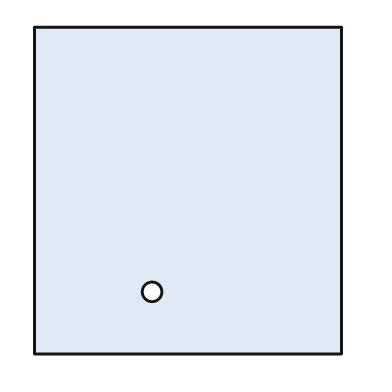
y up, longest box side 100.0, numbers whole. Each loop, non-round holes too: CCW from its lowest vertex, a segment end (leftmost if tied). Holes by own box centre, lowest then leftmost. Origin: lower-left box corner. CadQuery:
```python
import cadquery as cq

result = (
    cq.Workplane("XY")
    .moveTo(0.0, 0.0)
    .lineTo(94.0, 0.0)
    .lineTo(94.0, 100.0)
    .lineTo(0.0, 100.0)
    .close()
    .moveTo(36.0, 19.0)
    .circle(3.0)
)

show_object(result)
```